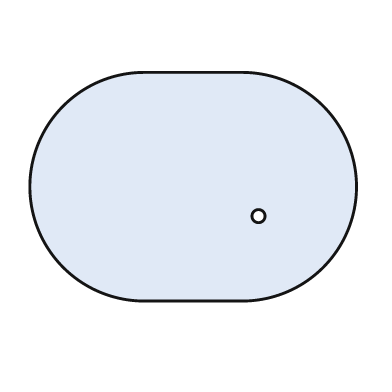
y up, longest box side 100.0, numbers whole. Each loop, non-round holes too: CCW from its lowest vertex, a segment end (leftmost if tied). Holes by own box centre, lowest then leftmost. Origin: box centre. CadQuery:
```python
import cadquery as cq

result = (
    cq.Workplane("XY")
    .moveTo(-15.0, -35.0)
    .lineTo(15.0, -35.0)
    .threePointArc((50.0, 0.0), (15.0, 35.0))
    .lineTo(-15.0, 35.0)
    .threePointArc((-50.0, 0.0), (-15.0, -35.0))
    .close()
    .moveTo(20.0, -9.0)
    .circle(2.0)
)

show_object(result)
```